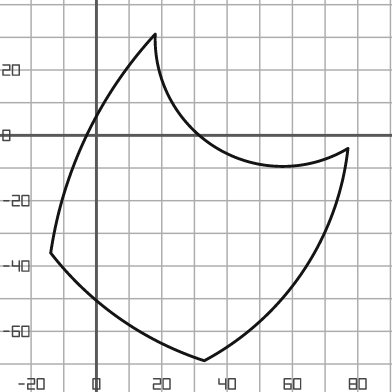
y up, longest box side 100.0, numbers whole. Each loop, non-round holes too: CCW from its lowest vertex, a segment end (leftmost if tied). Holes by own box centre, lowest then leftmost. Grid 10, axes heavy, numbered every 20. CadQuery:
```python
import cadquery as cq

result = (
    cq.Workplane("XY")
    .moveTo(33.0, -69.0)
    .threePointArc((63.0, -42.0), (77.0, -4.0))
    .threePointArc((37.0, -4.0), (18.0, 31.0))
    .threePointArc((-3.0, 0.0), (-14.0, -36.0))
    .threePointArc((7.0, -56.0), (33.0, -69.0))
    .close()
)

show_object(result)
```